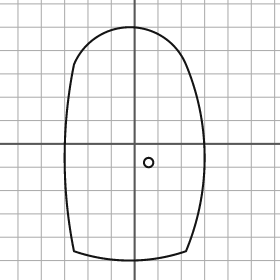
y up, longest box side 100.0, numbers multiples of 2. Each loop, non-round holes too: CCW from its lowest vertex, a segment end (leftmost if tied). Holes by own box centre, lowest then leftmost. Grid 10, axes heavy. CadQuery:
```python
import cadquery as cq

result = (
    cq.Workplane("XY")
    .moveTo(-26.0, -46.0)
    .threePointArc((-2.0, -50.0), (22.0, -46.0))
    .threePointArc((30.0, -6.0), (22.0, 34.0))
    .threePointArc((-2.0, 50.0), (-26.0, 34.0))
    .threePointArc((-30.0, -6.0), (-26.0, -46.0))
    .close()
    .moveTo(6.0, -8.0)
    .circle(2.0)
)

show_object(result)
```